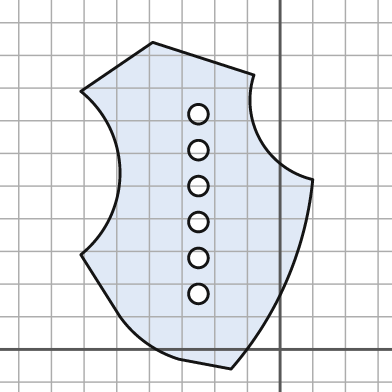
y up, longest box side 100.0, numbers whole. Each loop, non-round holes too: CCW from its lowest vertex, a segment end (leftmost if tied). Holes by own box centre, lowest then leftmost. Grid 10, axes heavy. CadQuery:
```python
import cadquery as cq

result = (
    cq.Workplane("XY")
    .moveTo(-15.0, -6.0)
    .threePointArc((2.0, 21.0), (10.0, 52.0))
    .threePointArc((-6.0, 64.0), (-8.0, 84.0))
    .lineTo(-39.0, 94.0)
    .lineTo(-61.0, 79.0)
    .threePointArc((-49.0, 54.0), (-61.0, 29.0))
    .lineTo(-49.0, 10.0)
    .threePointArc((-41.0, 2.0), (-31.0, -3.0))
    .close()
    .moveTo(-25.0, 17.0)
    .circle(3.0)
    .moveTo(-25.0, 28.0)
    .circle(3.0)
    .moveTo(-25.0, 39.0)
    .circle(3.0)
    .moveTo(-25.0, 50.0)
    .circle(3.0)
    .moveTo(-25.0, 61.0)
    .circle(3.0)
    .moveTo(-25.0, 72.0)
    .circle(3.0)
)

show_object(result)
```